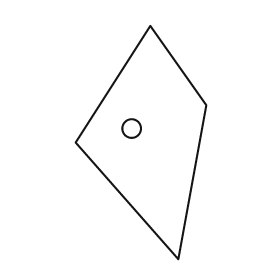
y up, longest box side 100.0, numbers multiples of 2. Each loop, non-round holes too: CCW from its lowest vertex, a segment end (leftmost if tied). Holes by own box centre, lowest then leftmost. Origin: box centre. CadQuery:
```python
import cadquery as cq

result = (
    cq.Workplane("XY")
    .moveTo(16.0, -50.0)
    .lineTo(28.0, 16.0)
    .lineTo(4.0, 50.0)
    .lineTo(-28.0, 0.0)
    .close()
    .moveTo(-4.0, 6.0)
    .circle(4.0)
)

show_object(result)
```